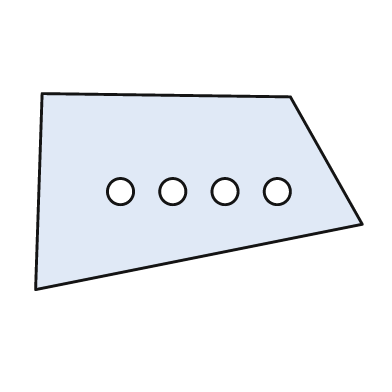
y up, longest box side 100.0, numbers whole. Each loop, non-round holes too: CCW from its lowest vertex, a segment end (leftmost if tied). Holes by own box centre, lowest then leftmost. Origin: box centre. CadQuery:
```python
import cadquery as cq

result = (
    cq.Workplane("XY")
    .moveTo(-50.0, -30.0)
    .lineTo(50.0, -10.0)
    .lineTo(28.0, 29.0)
    .lineTo(-48.0, 30.0)
    .close()
    .moveTo(-24.0, 0.0)
    .circle(4.0)
    .moveTo(-8.0, 0.0)
    .circle(4.0)
    .moveTo(8.0, 0.0)
    .circle(4.0)
    .moveTo(24.0, 0.0)
    .circle(4.0)
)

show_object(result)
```